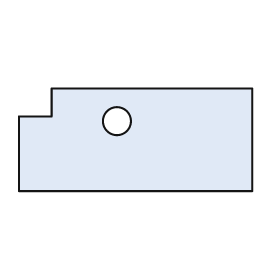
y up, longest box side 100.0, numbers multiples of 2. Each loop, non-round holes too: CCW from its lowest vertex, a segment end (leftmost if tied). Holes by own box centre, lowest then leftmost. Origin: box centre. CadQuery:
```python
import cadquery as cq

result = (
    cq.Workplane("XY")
    .moveTo(-50.0, -22.0)
    .lineTo(50.0, -22.0)
    .lineTo(50.0, 22.0)
    .lineTo(-36.0, 22.0)
    .lineTo(-36.0, 10.0)
    .lineTo(-50.0, 10.0)
    .close()
    .moveTo(-8.0, 8.0)
    .circle(6.0)
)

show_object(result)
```